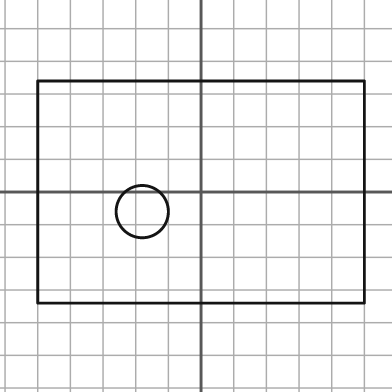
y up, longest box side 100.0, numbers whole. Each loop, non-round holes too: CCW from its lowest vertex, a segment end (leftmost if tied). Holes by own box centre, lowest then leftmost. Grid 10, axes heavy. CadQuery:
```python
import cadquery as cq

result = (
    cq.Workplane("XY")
    .moveTo(-50.0, -34.0)
    .lineTo(50.0, -34.0)
    .lineTo(50.0, 34.0)
    .lineTo(-50.0, 34.0)
    .close()
    .moveTo(-18.0, -6.0)
    .circle(8.0)
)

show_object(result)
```